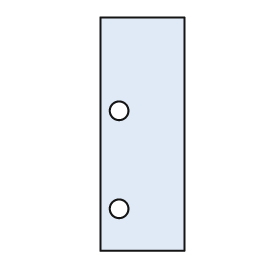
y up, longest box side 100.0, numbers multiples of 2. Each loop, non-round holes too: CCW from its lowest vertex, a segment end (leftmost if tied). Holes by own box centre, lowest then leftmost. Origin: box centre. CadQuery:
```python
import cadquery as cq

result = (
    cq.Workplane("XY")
    .moveTo(-18.0, -50.0)
    .lineTo(18.0, -50.0)
    .lineTo(18.0, 50.0)
    .lineTo(-18.0, 50.0)
    .close()
    .moveTo(-10.0, -32.0)
    .circle(4.0)
    .moveTo(-10.0, 10.0)
    .circle(4.0)
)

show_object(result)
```